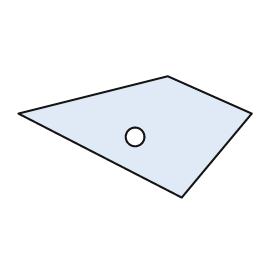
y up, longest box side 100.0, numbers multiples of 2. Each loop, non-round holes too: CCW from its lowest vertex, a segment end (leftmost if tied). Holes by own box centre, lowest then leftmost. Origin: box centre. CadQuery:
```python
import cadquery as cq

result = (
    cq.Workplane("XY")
    .moveTo(20.0, -26.0)
    .lineTo(50.0, 10.0)
    .lineTo(14.0, 26.0)
    .lineTo(-50.0, 10.0)
    .close()
    .moveTo(0.0, 0.0)
    .circle(4.0)
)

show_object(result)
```